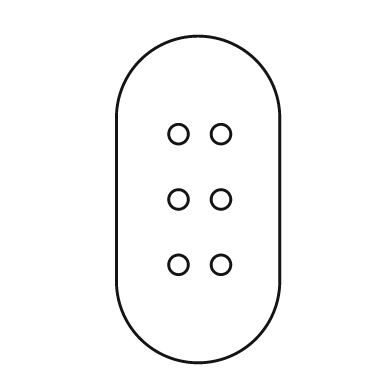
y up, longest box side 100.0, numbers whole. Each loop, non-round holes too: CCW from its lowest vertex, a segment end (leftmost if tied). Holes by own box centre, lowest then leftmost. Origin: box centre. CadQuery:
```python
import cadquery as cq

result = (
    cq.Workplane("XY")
    .moveTo(-25.0, -25.0)
    .threePointArc((0.0, -50.0), (25.0, -25.0))
    .lineTo(25.0, 25.0)
    .threePointArc((0.0, 50.0), (-25.0, 25.0))
    .close()
    .moveTo(-6.0, -20.0)
    .circle(3.0)
    .moveTo(7.0, -20.0)
    .circle(3.0)
    .moveTo(-6.0, 0.0)
    .circle(3.0)
    .moveTo(7.0, 0.0)
    .circle(3.0)
    .moveTo(-6.0, 20.0)
    .circle(3.0)
    .moveTo(7.0, 20.0)
    .circle(3.0)
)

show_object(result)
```